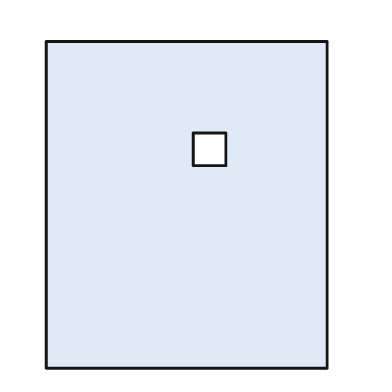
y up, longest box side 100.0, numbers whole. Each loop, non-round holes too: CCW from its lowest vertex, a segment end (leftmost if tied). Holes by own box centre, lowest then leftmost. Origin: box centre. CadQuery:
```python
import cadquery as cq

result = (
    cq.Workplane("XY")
    .moveTo(-43.0, -50.0)
    .lineTo(43.0, -50.0)
    .lineTo(43.0, 50.0)
    .lineTo(-43.0, 50.0)
    .close()
    .moveTo(2.0, 12.0)
    .lineTo(12.0, 12.0)
    .lineTo(12.0, 22.0)
    .lineTo(2.0, 22.0)
    .close()
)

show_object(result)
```